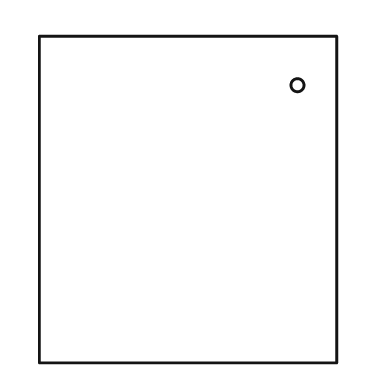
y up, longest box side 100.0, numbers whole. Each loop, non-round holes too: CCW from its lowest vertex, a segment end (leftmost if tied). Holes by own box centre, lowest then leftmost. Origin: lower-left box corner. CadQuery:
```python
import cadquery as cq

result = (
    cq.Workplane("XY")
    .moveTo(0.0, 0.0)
    .lineTo(91.0, 0.0)
    .lineTo(91.0, 100.0)
    .lineTo(0.0, 100.0)
    .close()
    .moveTo(79.0, 85.0)
    .circle(2.0)
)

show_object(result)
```